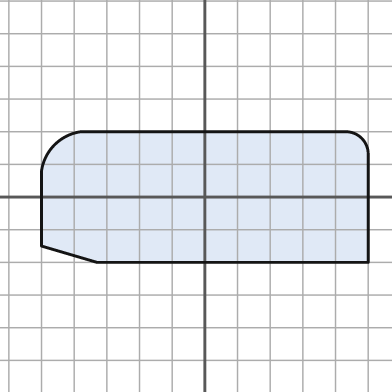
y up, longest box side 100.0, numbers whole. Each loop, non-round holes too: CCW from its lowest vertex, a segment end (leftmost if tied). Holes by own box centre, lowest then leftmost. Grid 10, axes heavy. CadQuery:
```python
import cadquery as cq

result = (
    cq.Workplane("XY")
    .moveTo(-33.0, -20.0)
    .lineTo(50.0, -20.0)
    .lineTo(50.0, 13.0)
    .threePointArc((48.0, 18.0), (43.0, 20.0))
    .lineTo(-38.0, 20.0)
    .threePointArc((-46.0, 16.0), (-50.0, 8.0))
    .lineTo(-50.0, -15.0)
    .close()
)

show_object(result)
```